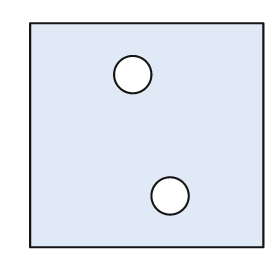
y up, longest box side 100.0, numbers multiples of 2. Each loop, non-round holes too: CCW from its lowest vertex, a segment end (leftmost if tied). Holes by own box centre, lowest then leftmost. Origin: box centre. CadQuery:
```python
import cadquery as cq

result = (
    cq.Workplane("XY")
    .moveTo(-50.0, -48.0)
    .lineTo(50.0, -48.0)
    .lineTo(50.0, 48.0)
    .lineTo(-50.0, 48.0)
    .close()
    .moveTo(10.0, -26.0)
    .circle(8.0)
    .moveTo(-6.0, 26.0)
    .circle(8.0)
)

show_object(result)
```